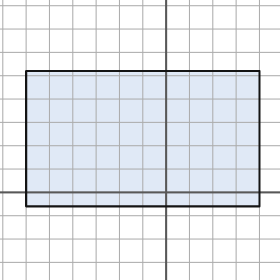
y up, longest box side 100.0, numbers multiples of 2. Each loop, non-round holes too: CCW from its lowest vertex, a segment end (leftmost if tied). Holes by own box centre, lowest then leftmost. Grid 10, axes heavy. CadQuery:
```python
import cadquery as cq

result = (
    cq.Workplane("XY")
    .moveTo(-60.0, -6.0)
    .lineTo(40.0, -6.0)
    .lineTo(40.0, 52.0)
    .lineTo(-60.0, 52.0)
    .close()
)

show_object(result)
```